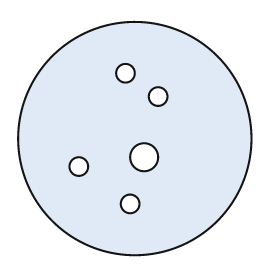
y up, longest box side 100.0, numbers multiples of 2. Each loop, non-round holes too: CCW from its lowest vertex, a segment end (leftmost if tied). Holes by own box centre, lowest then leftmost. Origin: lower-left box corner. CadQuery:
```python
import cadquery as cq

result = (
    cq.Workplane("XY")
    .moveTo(50.0, 50.0)
    .circle(50.0)
    .moveTo(48.0, 22.0)
    .circle(4.0)
    .moveTo(26.0, 38.0)
    .circle(4.0)
    .moveTo(54.0, 42.0)
    .circle(6.0)
    .moveTo(60.0, 68.0)
    .circle(4.0)
    .moveTo(46.0, 78.0)
    .circle(4.0)
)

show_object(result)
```